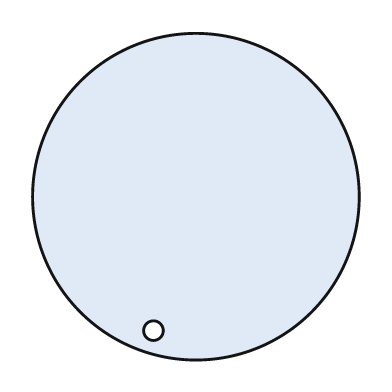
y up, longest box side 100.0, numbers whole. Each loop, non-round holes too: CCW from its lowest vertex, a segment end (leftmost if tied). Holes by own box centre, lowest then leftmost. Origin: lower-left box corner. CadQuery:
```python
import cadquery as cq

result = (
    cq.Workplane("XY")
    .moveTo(50.0, 50.0)
    .circle(50.0)
    .moveTo(37.0, 9.0)
    .circle(3.0)
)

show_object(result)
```